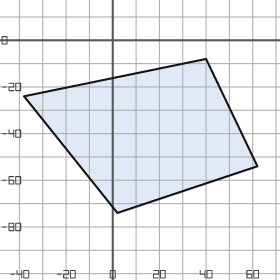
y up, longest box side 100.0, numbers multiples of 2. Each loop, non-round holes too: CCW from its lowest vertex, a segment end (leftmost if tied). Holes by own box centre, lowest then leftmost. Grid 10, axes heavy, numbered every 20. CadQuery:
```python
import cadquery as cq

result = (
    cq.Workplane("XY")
    .moveTo(2.0, -74.0)
    .lineTo(62.0, -54.0)
    .lineTo(40.0, -8.0)
    .lineTo(-38.0, -24.0)
    .close()
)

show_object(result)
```